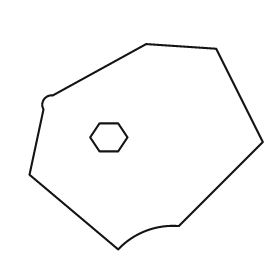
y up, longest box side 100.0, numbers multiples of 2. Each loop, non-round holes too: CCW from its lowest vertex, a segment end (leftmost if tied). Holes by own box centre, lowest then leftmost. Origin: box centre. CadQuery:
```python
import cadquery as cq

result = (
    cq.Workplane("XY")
    .moveTo(-12.0, -44.0)
    .threePointArc((0.0, -36.0), (14.0, -34.0))
    .lineTo(50.0, 2.0)
    .lineTo(30.0, 42.0)
    .lineTo(0.0, 44.0)
    .lineTo(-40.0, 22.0)
    .threePointArc((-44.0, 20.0), (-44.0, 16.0))
    .lineTo(-50.0, -12.0)
    .close()
    .moveTo(-20.0, -2.0)
    .lineTo(-12.0, -2.0)
    .lineTo(-8.0, 4.0)
    .lineTo(-12.0, 10.0)
    .lineTo(-20.0, 10.0)
    .lineTo(-24.0, 4.0)
    .close()
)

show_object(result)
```